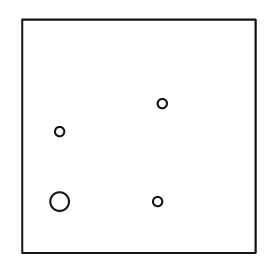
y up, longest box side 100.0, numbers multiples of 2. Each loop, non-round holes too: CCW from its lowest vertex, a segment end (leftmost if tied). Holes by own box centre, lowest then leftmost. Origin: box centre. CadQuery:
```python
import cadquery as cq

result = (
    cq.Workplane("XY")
    .moveTo(-50.0, -50.0)
    .lineTo(50.0, -50.0)
    .lineTo(50.0, 50.0)
    .lineTo(-50.0, 50.0)
    .close()
    .moveTo(-34.0, -28.0)
    .circle(4.0)
    .moveTo(8.0, -28.0)
    .circle(2.0)
    .moveTo(-34.0, 2.0)
    .circle(2.0)
    .moveTo(10.0, 14.0)
    .circle(2.0)
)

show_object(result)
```